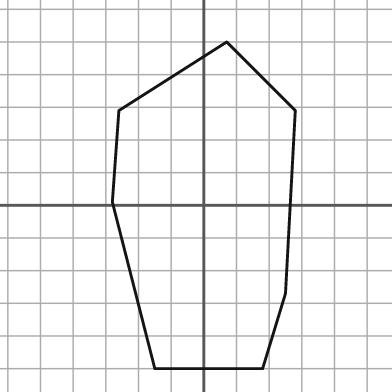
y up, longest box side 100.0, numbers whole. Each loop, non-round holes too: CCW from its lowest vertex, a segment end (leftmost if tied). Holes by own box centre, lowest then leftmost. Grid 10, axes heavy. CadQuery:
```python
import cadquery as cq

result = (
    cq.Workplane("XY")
    .moveTo(-15.0, -50.0)
    .lineTo(18.0, -50.0)
    .lineTo(25.0, -27.0)
    .lineTo(28.0, 29.0)
    .lineTo(7.0, 50.0)
    .lineTo(-26.0, 29.0)
    .lineTo(-28.0, 1.0)
    .close()
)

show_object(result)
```